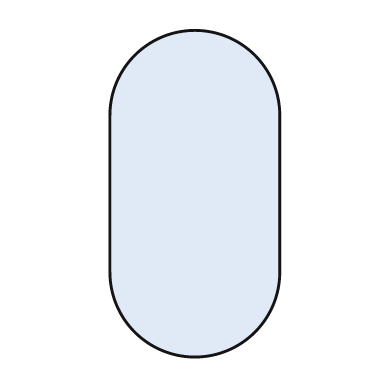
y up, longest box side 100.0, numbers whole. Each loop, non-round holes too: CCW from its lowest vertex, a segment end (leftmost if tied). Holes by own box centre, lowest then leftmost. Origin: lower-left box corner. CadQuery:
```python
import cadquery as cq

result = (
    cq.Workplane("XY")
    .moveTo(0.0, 26.0)
    .threePointArc((26.0, 0.0), (52.0, 26.0))
    .lineTo(52.0, 74.0)
    .threePointArc((26.0, 100.0), (0.0, 74.0))
    .close()
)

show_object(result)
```